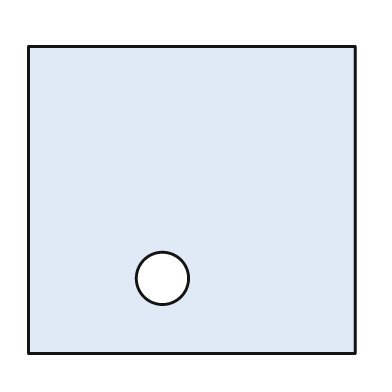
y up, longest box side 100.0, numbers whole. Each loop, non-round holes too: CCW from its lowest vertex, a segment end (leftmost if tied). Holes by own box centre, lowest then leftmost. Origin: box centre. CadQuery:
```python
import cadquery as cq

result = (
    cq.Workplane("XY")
    .moveTo(-50.0, -47.0)
    .lineTo(50.0, -47.0)
    .lineTo(50.0, 47.0)
    .lineTo(-50.0, 47.0)
    .close()
    .moveTo(-9.0, -24.0)
    .circle(8.0)
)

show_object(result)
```